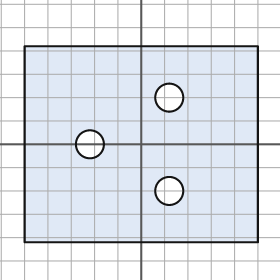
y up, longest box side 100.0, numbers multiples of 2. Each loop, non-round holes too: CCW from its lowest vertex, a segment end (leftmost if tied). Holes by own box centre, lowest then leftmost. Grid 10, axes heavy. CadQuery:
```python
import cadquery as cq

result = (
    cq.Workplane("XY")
    .moveTo(-50.0, -42.0)
    .lineTo(50.0, -42.0)
    .lineTo(50.0, 42.0)
    .lineTo(-50.0, 42.0)
    .close()
    .moveTo(12.0, -20.0)
    .circle(6.0)
    .moveTo(-22.0, 0.0)
    .circle(6.0)
    .moveTo(12.0, 20.0)
    .circle(6.0)
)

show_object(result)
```